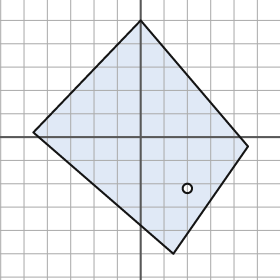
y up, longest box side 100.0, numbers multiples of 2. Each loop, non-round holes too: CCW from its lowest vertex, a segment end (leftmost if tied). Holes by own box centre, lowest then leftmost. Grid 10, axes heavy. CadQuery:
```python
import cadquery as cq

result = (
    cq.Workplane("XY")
    .moveTo(14.0, -50.0)
    .lineTo(46.0, -4.0)
    .lineTo(0.0, 50.0)
    .lineTo(-46.0, 2.0)
    .close()
    .moveTo(20.0, -22.0)
    .circle(2.0)
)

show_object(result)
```